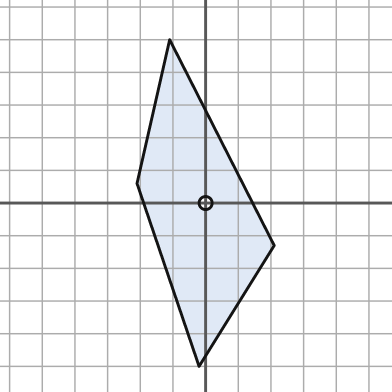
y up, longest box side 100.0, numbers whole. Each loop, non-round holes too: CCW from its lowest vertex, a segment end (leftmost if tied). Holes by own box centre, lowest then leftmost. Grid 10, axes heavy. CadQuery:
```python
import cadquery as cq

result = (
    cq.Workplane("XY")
    .moveTo(-2.0, -50.0)
    .lineTo(21.0, -13.0)
    .lineTo(-11.0, 50.0)
    .lineTo(-21.0, 6.0)
    .close()
    .moveTo(0.0, 0.0)
    .circle(2.0)
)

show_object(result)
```